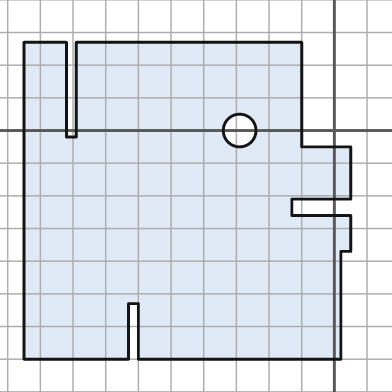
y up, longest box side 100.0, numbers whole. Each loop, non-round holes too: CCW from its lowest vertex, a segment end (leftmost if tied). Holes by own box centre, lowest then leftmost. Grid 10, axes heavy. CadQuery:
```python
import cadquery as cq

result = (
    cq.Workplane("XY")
    .moveTo(-95.0, -70.0)
    .lineTo(-63.0, -70.0)
    .lineTo(-63.0, -53.0)
    .lineTo(-60.0, -53.0)
    .lineTo(-60.0, -70.0)
    .lineTo(2.0, -70.0)
    .lineTo(2.0, -37.0)
    .lineTo(5.0, -37.0)
    .lineTo(5.0, -26.0)
    .lineTo(-13.0, -26.0)
    .lineTo(-13.0, -21.0)
    .lineTo(5.0, -21.0)
    .lineTo(5.0, -5.0)
    .lineTo(-10.0, -5.0)
    .lineTo(-10.0, 27.0)
    .lineTo(-79.0, 27.0)
    .lineTo(-79.0, -2.0)
    .lineTo(-82.0, -2.0)
    .lineTo(-82.0, 27.0)
    .lineTo(-95.0, 27.0)
    .close()
    .moveTo(-29.0, 0.0)
    .circle(5.0)
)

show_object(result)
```